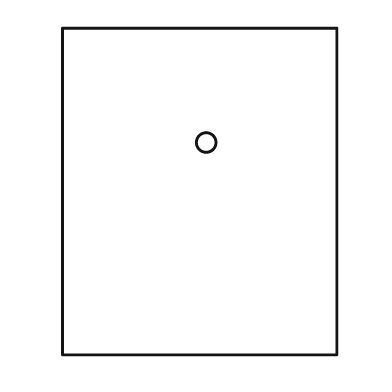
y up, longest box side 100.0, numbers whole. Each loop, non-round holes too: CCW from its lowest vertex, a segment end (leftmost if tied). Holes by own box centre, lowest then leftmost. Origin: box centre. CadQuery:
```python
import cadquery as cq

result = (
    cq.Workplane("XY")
    .moveTo(-42.0, -50.0)
    .lineTo(42.0, -50.0)
    .lineTo(42.0, 50.0)
    .lineTo(-42.0, 50.0)
    .close()
    .moveTo(2.0, 15.0)
    .circle(3.0)
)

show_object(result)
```